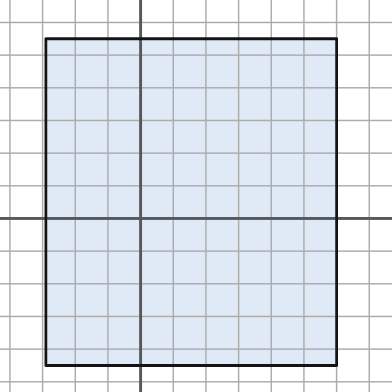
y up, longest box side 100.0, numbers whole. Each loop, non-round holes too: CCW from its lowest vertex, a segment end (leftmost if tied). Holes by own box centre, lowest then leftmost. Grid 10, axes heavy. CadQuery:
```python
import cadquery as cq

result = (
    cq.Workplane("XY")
    .moveTo(-29.0, -45.0)
    .lineTo(60.0, -45.0)
    .lineTo(60.0, 55.0)
    .lineTo(-29.0, 55.0)
    .close()
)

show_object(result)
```